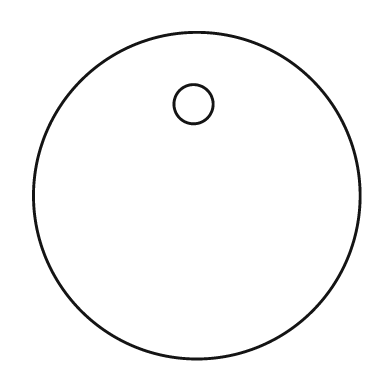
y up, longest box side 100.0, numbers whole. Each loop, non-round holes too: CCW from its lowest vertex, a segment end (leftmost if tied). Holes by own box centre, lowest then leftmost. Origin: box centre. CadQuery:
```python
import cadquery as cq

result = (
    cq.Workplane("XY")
    .moveTo(0.0, 0.0)
    .circle(50.0)
    .moveTo(-1.0, 28.0)
    .circle(6.0)
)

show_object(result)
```